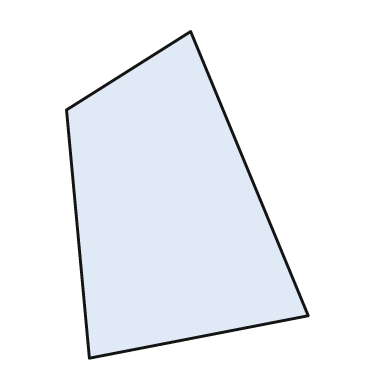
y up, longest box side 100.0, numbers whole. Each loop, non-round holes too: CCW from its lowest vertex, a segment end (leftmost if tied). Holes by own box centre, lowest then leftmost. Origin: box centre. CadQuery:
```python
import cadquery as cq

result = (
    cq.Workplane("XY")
    .moveTo(-30.0, -50.0)
    .lineTo(37.0, -37.0)
    .lineTo(1.0, 50.0)
    .lineTo(-37.0, 26.0)
    .close()
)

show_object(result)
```